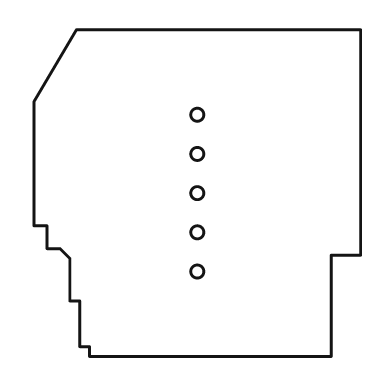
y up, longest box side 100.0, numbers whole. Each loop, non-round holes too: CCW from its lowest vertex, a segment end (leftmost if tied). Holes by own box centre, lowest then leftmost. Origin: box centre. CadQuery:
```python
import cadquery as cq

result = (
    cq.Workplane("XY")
    .moveTo(-33.0, -50.0)
    .lineTo(41.0, -50.0)
    .lineTo(41.0, -19.0)
    .lineTo(50.0, -19.0)
    .lineTo(50.0, 50.0)
    .lineTo(-37.0, 50.0)
    .lineTo(-50.0, 28.0)
    .lineTo(-50.0, -10.0)
    .lineTo(-46.0, -10.0)
    .lineTo(-46.0, -17.0)
    .lineTo(-42.0, -17.0)
    .lineTo(-39.0, -20.0)
    .lineTo(-39.0, -33.0)
    .lineTo(-36.0, -33.0)
    .lineTo(-36.0, -47.0)
    .lineTo(-33.0, -47.0)
    .close()
    .moveTo(0.0, -24.0)
    .circle(2.0)
    .moveTo(0.0, -12.0)
    .circle(2.0)
    .moveTo(0.0, 0.0)
    .circle(2.0)
    .moveTo(0.0, 12.0)
    .circle(2.0)
    .moveTo(0.0, 24.0)
    .circle(2.0)
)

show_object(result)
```